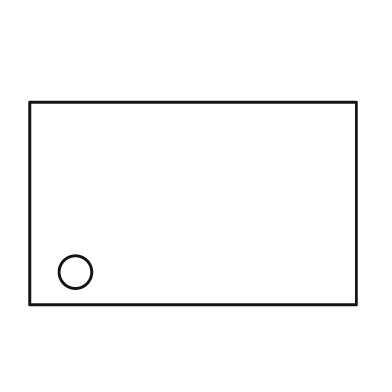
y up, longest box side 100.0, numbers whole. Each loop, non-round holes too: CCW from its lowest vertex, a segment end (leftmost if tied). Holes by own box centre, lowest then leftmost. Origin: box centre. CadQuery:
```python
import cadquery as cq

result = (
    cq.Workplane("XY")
    .moveTo(-50.0, -31.0)
    .lineTo(50.0, -31.0)
    .lineTo(50.0, 31.0)
    .lineTo(-50.0, 31.0)
    .close()
    .moveTo(-36.0, -21.0)
    .circle(5.0)
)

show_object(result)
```